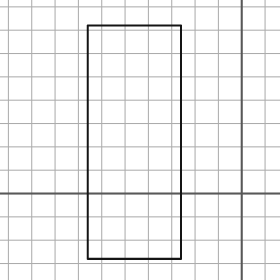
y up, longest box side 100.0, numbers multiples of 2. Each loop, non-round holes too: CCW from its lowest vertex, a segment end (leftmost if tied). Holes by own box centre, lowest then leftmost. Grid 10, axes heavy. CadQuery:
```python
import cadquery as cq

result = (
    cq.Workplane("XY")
    .moveTo(-66.0, -28.0)
    .lineTo(-26.0, -28.0)
    .lineTo(-26.0, 72.0)
    .lineTo(-66.0, 72.0)
    .close()
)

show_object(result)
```